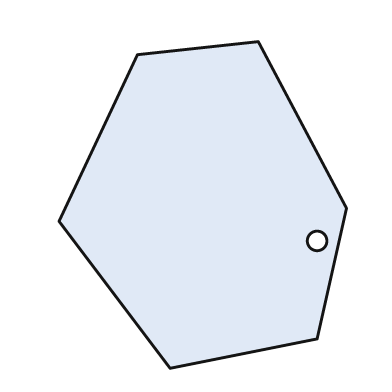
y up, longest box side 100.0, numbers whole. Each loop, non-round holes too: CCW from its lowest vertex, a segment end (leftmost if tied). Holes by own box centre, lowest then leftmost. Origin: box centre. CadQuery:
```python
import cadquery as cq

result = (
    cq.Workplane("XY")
    .moveTo(-10.0, -50.0)
    .lineTo(35.0, -41.0)
    .lineTo(44.0, -1.0)
    .lineTo(17.0, 50.0)
    .lineTo(-20.0, 46.0)
    .lineTo(-44.0, -5.0)
    .close()
    .moveTo(35.0, -11.0)
    .circle(3.0)
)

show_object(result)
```